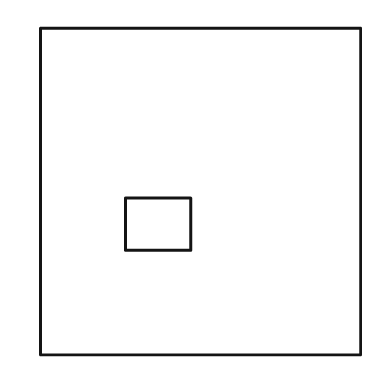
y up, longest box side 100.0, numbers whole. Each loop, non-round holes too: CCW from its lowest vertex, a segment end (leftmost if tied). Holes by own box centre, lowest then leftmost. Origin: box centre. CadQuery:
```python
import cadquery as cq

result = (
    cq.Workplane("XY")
    .moveTo(-49.0, -50.0)
    .lineTo(49.0, -50.0)
    .lineTo(49.0, 50.0)
    .lineTo(-49.0, 50.0)
    .close()
    .moveTo(-23.0, -18.0)
    .lineTo(-3.0, -18.0)
    .lineTo(-3.0, -2.0)
    .lineTo(-23.0, -2.0)
    .close()
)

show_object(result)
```